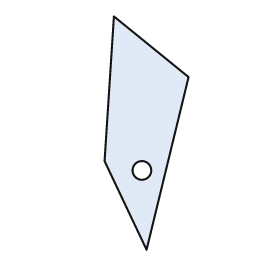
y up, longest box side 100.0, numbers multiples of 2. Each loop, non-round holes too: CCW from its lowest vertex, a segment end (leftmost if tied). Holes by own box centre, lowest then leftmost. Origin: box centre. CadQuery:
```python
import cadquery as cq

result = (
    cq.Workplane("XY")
    .moveTo(0.0, -50.0)
    .lineTo(18.0, 24.0)
    .lineTo(-14.0, 50.0)
    .lineTo(-18.0, -12.0)
    .close()
    .moveTo(-2.0, -16.0)
    .circle(4.0)
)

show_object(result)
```